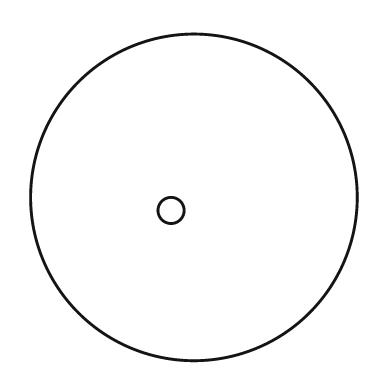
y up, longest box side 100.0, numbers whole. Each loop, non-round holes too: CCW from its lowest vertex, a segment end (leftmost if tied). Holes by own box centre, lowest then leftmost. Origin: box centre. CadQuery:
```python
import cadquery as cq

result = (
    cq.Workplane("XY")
    .moveTo(0.0, 0.0)
    .circle(50.0)
    .moveTo(-7.0, -4.0)
    .circle(4.0)
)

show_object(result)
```